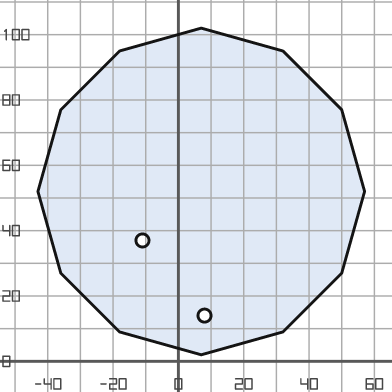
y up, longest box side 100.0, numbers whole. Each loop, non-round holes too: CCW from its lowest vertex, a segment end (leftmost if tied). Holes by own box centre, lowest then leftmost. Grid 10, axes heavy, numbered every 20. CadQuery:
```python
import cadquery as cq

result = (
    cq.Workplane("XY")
    .moveTo(7.0, 2.0)
    .lineTo(32.0, 9.0)
    .lineTo(50.0, 27.0)
    .lineTo(57.0, 52.0)
    .lineTo(50.0, 77.0)
    .lineTo(32.0, 95.0)
    .lineTo(7.0, 102.0)
    .lineTo(-18.0, 95.0)
    .lineTo(-36.0, 77.0)
    .lineTo(-43.0, 52.0)
    .lineTo(-36.0, 27.0)
    .lineTo(-18.0, 9.0)
    .close()
    .moveTo(8.0, 14.0)
    .circle(2.0)
    .moveTo(-11.0, 37.0)
    .circle(2.0)
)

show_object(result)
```